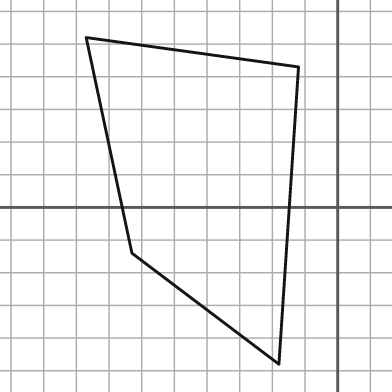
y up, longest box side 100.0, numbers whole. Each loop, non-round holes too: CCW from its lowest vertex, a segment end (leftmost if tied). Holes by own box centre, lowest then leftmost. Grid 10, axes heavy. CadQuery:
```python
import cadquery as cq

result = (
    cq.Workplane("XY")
    .moveTo(-18.0, -48.0)
    .lineTo(-12.0, 43.0)
    .lineTo(-77.0, 52.0)
    .lineTo(-63.0, -14.0)
    .close()
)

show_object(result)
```